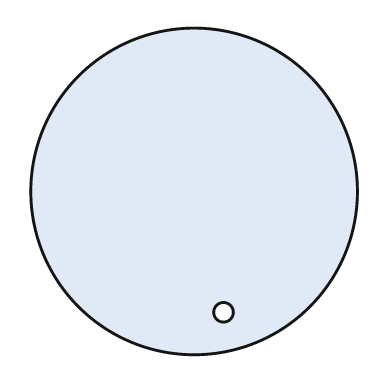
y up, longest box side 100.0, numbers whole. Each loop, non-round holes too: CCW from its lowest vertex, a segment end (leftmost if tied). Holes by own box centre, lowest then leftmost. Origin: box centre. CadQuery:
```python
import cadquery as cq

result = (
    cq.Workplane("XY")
    .moveTo(0.0, 0.0)
    .circle(50.0)
    .moveTo(9.0, -37.0)
    .circle(3.0)
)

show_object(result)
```